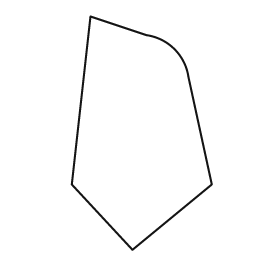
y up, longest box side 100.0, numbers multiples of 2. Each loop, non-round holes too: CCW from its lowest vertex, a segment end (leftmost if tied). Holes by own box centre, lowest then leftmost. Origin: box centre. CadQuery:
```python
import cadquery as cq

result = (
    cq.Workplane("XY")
    .moveTo(-4.0, -50.0)
    .lineTo(30.0, -22.0)
    .lineTo(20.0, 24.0)
    .threePointArc((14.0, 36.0), (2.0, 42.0))
    .lineTo(-22.0, 50.0)
    .lineTo(-30.0, -22.0)
    .close()
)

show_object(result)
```